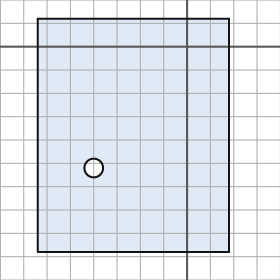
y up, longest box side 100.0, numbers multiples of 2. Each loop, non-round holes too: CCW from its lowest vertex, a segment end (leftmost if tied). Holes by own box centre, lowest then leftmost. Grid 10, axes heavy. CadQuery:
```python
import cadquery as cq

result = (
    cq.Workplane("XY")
    .moveTo(-64.0, -88.0)
    .lineTo(18.0, -88.0)
    .lineTo(18.0, 12.0)
    .lineTo(-64.0, 12.0)
    .close()
    .moveTo(-40.0, -52.0)
    .circle(4.0)
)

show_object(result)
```